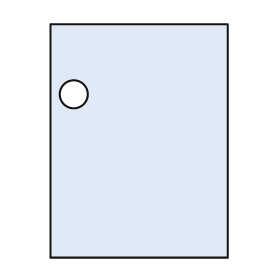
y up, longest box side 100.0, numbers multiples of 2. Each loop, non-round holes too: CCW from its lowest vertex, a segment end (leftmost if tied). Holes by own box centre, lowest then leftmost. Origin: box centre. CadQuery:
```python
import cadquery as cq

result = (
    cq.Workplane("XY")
    .moveTo(-38.0, -50.0)
    .lineTo(38.0, -50.0)
    .lineTo(38.0, 50.0)
    .lineTo(-38.0, 50.0)
    .close()
    .moveTo(-28.0, 20.0)
    .circle(6.0)
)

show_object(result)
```